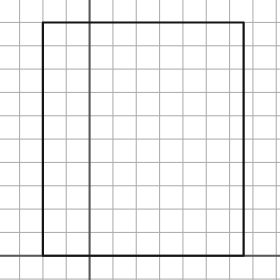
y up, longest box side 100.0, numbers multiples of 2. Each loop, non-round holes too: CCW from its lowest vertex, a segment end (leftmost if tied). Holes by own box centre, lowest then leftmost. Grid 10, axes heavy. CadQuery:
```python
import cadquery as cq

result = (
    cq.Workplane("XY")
    .moveTo(-20.0, 0.0)
    .lineTo(66.0, 0.0)
    .lineTo(66.0, 100.0)
    .lineTo(-20.0, 100.0)
    .close()
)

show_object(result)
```